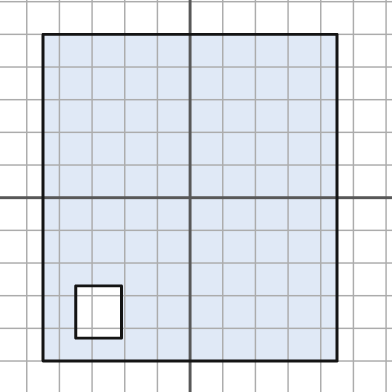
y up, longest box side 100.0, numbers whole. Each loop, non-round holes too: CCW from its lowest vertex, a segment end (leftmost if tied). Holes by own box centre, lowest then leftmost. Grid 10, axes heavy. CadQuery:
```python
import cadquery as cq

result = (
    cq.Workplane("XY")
    .moveTo(-45.0, -50.0)
    .lineTo(45.0, -50.0)
    .lineTo(45.0, 50.0)
    .lineTo(-45.0, 50.0)
    .close()
    .moveTo(-35.0, -43.0)
    .lineTo(-21.0, -43.0)
    .lineTo(-21.0, -27.0)
    .lineTo(-35.0, -27.0)
    .close()
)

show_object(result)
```